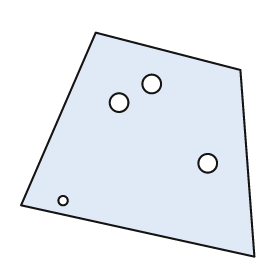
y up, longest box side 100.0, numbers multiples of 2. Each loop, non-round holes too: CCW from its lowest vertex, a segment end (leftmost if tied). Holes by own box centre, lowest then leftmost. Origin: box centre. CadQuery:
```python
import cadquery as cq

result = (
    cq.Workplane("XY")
    .moveTo(50.0, -48.0)
    .lineTo(44.0, 32.0)
    .lineTo(-18.0, 48.0)
    .lineTo(-50.0, -26.0)
    .close()
    .moveTo(-32.0, -24.0)
    .circle(2.0)
    .moveTo(30.0, -8.0)
    .circle(4.0)
    .moveTo(-8.0, 18.0)
    .circle(4.0)
    .moveTo(6.0, 26.0)
    .circle(4.0)
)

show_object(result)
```